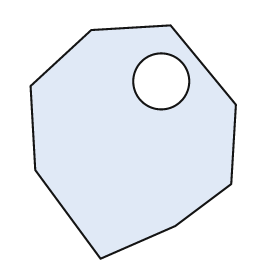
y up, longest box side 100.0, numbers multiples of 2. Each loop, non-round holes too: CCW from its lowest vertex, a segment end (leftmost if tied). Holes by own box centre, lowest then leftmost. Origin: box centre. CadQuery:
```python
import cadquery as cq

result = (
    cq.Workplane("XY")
    .moveTo(-14.0, -50.0)
    .lineTo(18.0, -36.0)
    .lineTo(42.0, -18.0)
    .lineTo(44.0, 16.0)
    .lineTo(16.0, 50.0)
    .lineTo(-18.0, 48.0)
    .lineTo(-44.0, 24.0)
    .lineTo(-42.0, -12.0)
    .close()
    .moveTo(12.0, 26.0)
    .circle(12.0)
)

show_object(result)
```